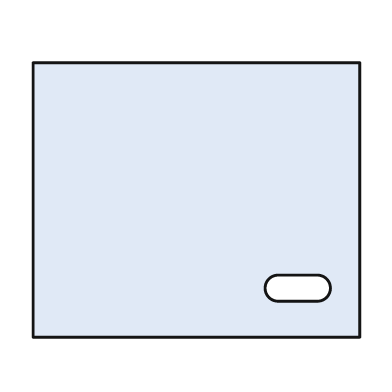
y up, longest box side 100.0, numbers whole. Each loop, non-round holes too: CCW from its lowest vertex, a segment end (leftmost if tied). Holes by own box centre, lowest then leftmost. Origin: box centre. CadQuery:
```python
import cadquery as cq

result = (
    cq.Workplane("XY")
    .moveTo(-50.0, -42.0)
    .lineTo(50.0, -42.0)
    .lineTo(50.0, 42.0)
    .lineTo(-50.0, 42.0)
    .close()
    .moveTo(25.0, -31.0)
    .lineTo(37.0, -31.0)
    .threePointArc((41.0, -27.0), (37.0, -23.0))
    .lineTo(25.0, -23.0)
    .threePointArc((21.0, -27.0), (25.0, -31.0))
    .close()
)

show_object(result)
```